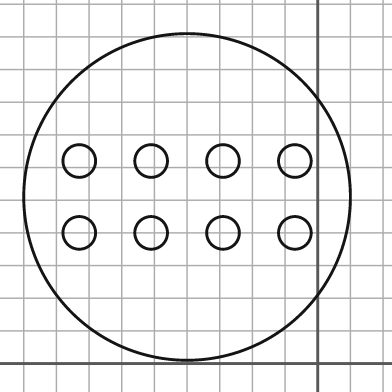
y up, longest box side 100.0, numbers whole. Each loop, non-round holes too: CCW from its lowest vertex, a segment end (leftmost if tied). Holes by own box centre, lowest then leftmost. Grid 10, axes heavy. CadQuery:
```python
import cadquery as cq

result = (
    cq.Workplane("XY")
    .moveTo(-40.0, 51.0)
    .circle(50.0)
    .moveTo(-73.0, 40.0)
    .circle(5.0)
    .moveTo(-51.0, 40.0)
    .circle(5.0)
    .moveTo(-29.0, 40.0)
    .circle(5.0)
    .moveTo(-7.0, 40.0)
    .circle(5.0)
    .moveTo(-73.0, 62.0)
    .circle(5.0)
    .moveTo(-51.0, 62.0)
    .circle(5.0)
    .moveTo(-29.0, 62.0)
    .circle(5.0)
    .moveTo(-7.0, 62.0)
    .circle(5.0)
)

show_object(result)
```